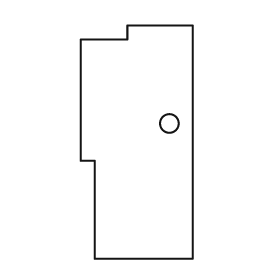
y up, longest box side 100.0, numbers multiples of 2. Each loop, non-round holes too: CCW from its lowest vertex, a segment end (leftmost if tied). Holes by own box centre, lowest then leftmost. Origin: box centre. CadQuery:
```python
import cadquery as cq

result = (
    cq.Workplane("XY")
    .moveTo(-18.0, -50.0)
    .lineTo(24.0, -50.0)
    .lineTo(24.0, 50.0)
    .lineTo(-4.0, 50.0)
    .lineTo(-4.0, 44.0)
    .lineTo(-24.0, 44.0)
    .lineTo(-24.0, -8.0)
    .lineTo(-18.0, -8.0)
    .close()
    .moveTo(14.0, 8.0)
    .circle(4.0)
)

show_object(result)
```